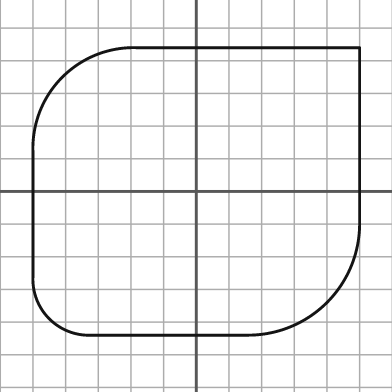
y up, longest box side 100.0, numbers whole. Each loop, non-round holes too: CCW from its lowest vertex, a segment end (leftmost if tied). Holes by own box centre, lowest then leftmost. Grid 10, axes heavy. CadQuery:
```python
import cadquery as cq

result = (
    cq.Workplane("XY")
    .moveTo(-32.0, -44.0)
    .lineTo(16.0, -44.0)
    .threePointArc((40.0, -34.0), (50.0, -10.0))
    .lineTo(50.0, 44.0)
    .lineTo(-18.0, 44.0)
    .threePointArc((-41.0, 35.0), (-50.0, 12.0))
    .lineTo(-50.0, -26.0)
    .threePointArc((-45.0, -39.0), (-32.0, -44.0))
    .close()
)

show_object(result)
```